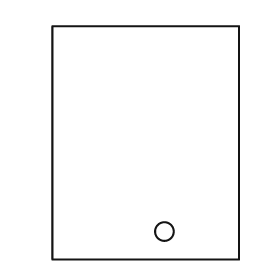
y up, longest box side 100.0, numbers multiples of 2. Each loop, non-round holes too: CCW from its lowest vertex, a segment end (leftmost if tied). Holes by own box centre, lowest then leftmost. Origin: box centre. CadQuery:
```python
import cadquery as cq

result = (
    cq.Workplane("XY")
    .moveTo(-40.0, -50.0)
    .lineTo(40.0, -50.0)
    .lineTo(40.0, 50.0)
    .lineTo(-40.0, 50.0)
    .close()
    .moveTo(8.0, -38.0)
    .circle(4.0)
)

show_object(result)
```